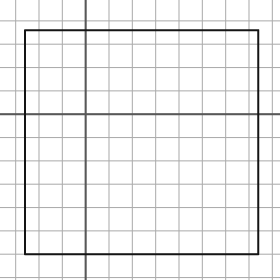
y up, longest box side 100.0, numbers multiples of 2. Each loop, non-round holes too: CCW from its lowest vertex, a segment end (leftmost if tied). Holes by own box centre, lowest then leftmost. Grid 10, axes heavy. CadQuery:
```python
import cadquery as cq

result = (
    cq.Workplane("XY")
    .moveTo(-26.0, -60.0)
    .lineTo(74.0, -60.0)
    .lineTo(74.0, 36.0)
    .lineTo(-26.0, 36.0)
    .close()
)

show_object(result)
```